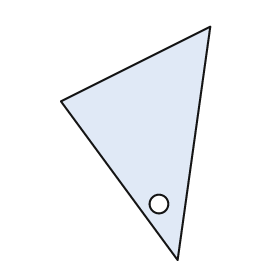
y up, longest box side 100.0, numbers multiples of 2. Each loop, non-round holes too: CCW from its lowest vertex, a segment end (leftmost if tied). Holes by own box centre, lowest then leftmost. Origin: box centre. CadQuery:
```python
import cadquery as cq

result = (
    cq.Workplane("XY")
    .moveTo(18.0, -50.0)
    .lineTo(32.0, 50.0)
    .lineTo(-32.0, 18.0)
    .close()
    .moveTo(10.0, -26.0)
    .circle(4.0)
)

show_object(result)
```